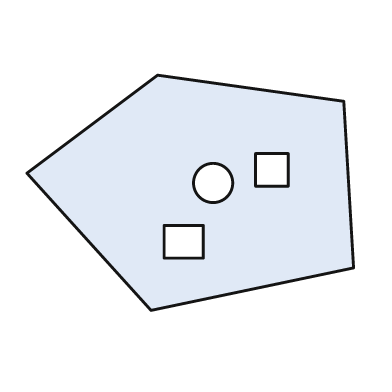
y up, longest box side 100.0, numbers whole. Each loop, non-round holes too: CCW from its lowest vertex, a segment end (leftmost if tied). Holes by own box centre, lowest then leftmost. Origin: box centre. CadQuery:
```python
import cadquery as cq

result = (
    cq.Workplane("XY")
    .moveTo(-12.0, -36.0)
    .lineTo(50.0, -23.0)
    .lineTo(47.0, 28.0)
    .lineTo(-10.0, 36.0)
    .lineTo(-50.0, 6.0)
    .close()
    .moveTo(-8.0, -20.0)
    .lineTo(4.0, -20.0)
    .lineTo(4.0, -10.0)
    .lineTo(-8.0, -10.0)
    .close()
    .moveTo(7.0, 3.0)
    .circle(6.0)
    .moveTo(20.0, 2.0)
    .lineTo(30.0, 2.0)
    .lineTo(30.0, 12.0)
    .lineTo(20.0, 12.0)
    .close()
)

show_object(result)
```